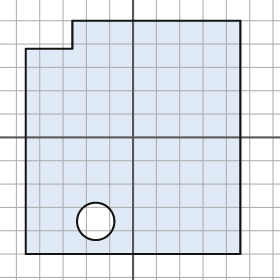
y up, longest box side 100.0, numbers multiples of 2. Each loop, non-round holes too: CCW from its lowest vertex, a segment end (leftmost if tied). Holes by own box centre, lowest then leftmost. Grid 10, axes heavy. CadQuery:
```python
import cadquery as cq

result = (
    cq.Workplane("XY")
    .moveTo(-46.0, -50.0)
    .lineTo(46.0, -50.0)
    .lineTo(46.0, 50.0)
    .lineTo(-26.0, 50.0)
    .lineTo(-26.0, 38.0)
    .lineTo(-46.0, 38.0)
    .close()
    .moveTo(-16.0, -36.0)
    .circle(8.0)
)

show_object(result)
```